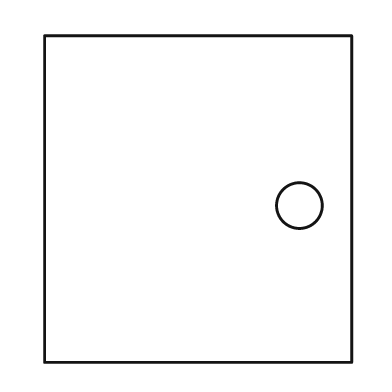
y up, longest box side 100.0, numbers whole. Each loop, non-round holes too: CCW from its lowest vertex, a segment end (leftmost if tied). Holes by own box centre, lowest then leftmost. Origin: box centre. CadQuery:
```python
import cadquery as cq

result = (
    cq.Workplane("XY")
    .moveTo(-47.0, -50.0)
    .lineTo(47.0, -50.0)
    .lineTo(47.0, 50.0)
    .lineTo(-47.0, 50.0)
    .close()
    .moveTo(31.0, -2.0)
    .circle(7.0)
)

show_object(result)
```